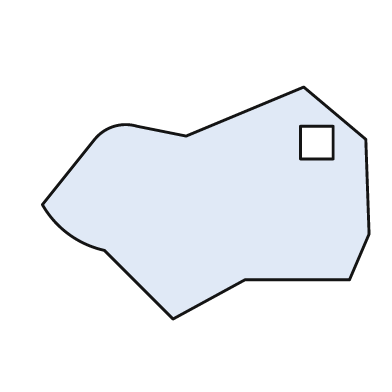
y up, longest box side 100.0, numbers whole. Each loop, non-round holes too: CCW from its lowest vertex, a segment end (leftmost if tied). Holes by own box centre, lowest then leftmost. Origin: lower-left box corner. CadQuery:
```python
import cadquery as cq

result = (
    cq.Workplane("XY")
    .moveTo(40.0, 0.0)
    .lineTo(62.0, 12.0)
    .lineTo(94.0, 12.0)
    .lineTo(100.0, 26.0)
    .lineTo(99.0, 55.0)
    .lineTo(80.0, 71.0)
    .lineTo(44.0, 56.0)
    .lineTo(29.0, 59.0)
    .threePointArc((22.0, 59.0), (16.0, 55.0))
    .lineTo(0.0, 35.0)
    .threePointArc((8.0, 26.0), (19.0, 21.0))
    .close()
    .moveTo(79.0, 49.0)
    .lineTo(89.0, 49.0)
    .lineTo(89.0, 59.0)
    .lineTo(79.0, 59.0)
    .close()
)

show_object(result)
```